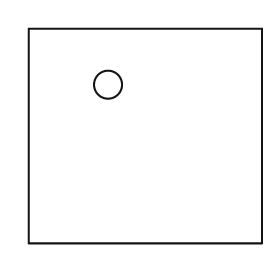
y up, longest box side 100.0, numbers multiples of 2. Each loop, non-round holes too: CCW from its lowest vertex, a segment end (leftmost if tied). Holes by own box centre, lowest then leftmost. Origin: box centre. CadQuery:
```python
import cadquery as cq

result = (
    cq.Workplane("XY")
    .moveTo(-50.0, -46.0)
    .lineTo(50.0, -46.0)
    .lineTo(50.0, 46.0)
    .lineTo(-50.0, 46.0)
    .close()
    .moveTo(-16.0, 22.0)
    .circle(6.0)
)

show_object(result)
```